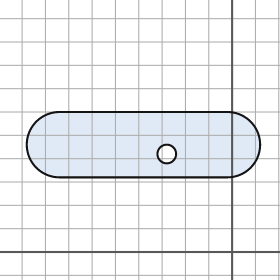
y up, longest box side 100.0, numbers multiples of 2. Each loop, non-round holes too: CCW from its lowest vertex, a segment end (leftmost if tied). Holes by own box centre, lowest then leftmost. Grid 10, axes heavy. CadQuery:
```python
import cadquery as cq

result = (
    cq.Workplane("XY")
    .moveTo(-74.0, 32.0)
    .lineTo(-2.0, 32.0)
    .threePointArc((12.0, 46.0), (-2.0, 60.0))
    .lineTo(-74.0, 60.0)
    .threePointArc((-88.0, 46.0), (-74.0, 32.0))
    .close()
    .moveTo(-28.0, 42.0)
    .circle(4.0)
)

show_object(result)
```